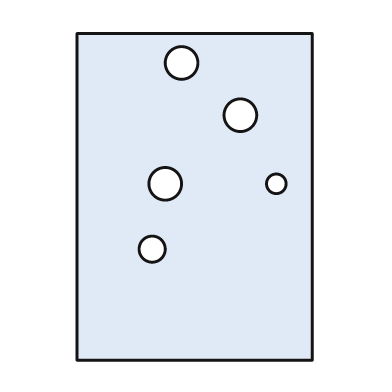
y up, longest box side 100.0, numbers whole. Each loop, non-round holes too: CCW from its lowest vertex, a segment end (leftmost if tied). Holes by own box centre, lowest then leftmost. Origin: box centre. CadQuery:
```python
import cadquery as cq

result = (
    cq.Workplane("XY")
    .moveTo(-36.0, -50.0)
    .lineTo(36.0, -50.0)
    .lineTo(36.0, 50.0)
    .lineTo(-36.0, 50.0)
    .close()
    .moveTo(-13.0, -16.0)
    .circle(4.0)
    .moveTo(-9.0, 4.0)
    .circle(5.0)
    .moveTo(25.0, 4.0)
    .circle(3.0)
    .moveTo(14.0, 25.0)
    .circle(5.0)
    .moveTo(-4.0, 41.0)
    .circle(5.0)
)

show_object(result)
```